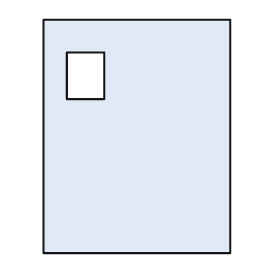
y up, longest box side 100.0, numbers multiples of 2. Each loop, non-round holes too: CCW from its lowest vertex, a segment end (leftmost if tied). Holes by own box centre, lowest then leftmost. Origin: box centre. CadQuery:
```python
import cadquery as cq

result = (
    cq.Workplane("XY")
    .moveTo(-40.0, -50.0)
    .lineTo(40.0, -50.0)
    .lineTo(40.0, 50.0)
    .lineTo(-40.0, 50.0)
    .close()
    .moveTo(-30.0, 16.0)
    .lineTo(-14.0, 16.0)
    .lineTo(-14.0, 36.0)
    .lineTo(-30.0, 36.0)
    .close()
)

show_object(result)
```